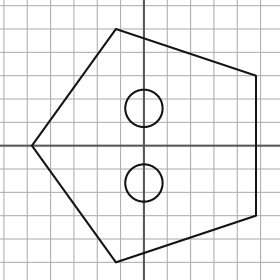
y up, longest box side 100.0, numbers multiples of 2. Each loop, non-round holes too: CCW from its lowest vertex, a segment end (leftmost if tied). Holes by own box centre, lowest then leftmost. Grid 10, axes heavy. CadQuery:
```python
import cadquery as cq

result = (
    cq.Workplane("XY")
    .moveTo(-12.0, -50.0)
    .lineTo(48.0, -30.0)
    .lineTo(48.0, 30.0)
    .lineTo(-12.0, 50.0)
    .lineTo(-48.0, 0.0)
    .close()
    .moveTo(0.0, -16.0)
    .circle(8.0)
    .moveTo(0.0, 16.0)
    .circle(8.0)
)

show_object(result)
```